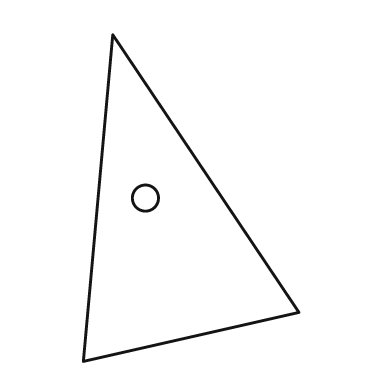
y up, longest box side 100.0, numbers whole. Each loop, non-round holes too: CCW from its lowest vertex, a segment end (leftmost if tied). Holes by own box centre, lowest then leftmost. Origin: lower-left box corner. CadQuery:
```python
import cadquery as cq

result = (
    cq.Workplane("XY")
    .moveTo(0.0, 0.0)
    .lineTo(66.0, 15.0)
    .lineTo(9.0, 100.0)
    .close()
    .moveTo(19.0, 50.0)
    .circle(4.0)
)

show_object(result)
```